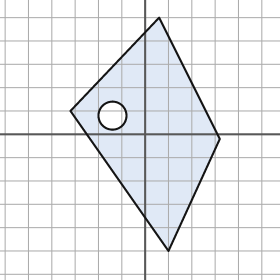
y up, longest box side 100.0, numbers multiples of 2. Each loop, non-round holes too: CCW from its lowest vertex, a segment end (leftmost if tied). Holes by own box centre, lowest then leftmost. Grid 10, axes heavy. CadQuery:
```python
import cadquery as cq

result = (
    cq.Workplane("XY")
    .moveTo(10.0, -50.0)
    .lineTo(32.0, -2.0)
    .lineTo(6.0, 50.0)
    .lineTo(-32.0, 10.0)
    .close()
    .moveTo(-14.0, 8.0)
    .circle(6.0)
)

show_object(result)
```